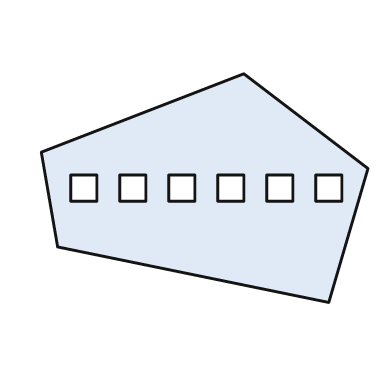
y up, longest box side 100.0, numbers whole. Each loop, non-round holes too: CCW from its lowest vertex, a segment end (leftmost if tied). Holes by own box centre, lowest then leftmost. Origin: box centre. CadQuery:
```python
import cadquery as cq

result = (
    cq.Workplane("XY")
    .moveTo(38.0, -35.0)
    .lineTo(50.0, 6.0)
    .lineTo(12.0, 35.0)
    .lineTo(-50.0, 11.0)
    .lineTo(-45.0, -18.0)
    .close()
    .moveTo(-41.0, -4.0)
    .lineTo(-33.0, -4.0)
    .lineTo(-33.0, 4.0)
    .lineTo(-41.0, 4.0)
    .close()
    .moveTo(-26.0, -4.0)
    .lineTo(-18.0, -4.0)
    .lineTo(-18.0, 4.0)
    .lineTo(-26.0, 4.0)
    .close()
    .moveTo(-11.0, -4.0)
    .lineTo(-3.0, -4.0)
    .lineTo(-3.0, 4.0)
    .lineTo(-11.0, 4.0)
    .close()
    .moveTo(4.0, -4.0)
    .lineTo(12.0, -4.0)
    .lineTo(12.0, 4.0)
    .lineTo(4.0, 4.0)
    .close()
    .moveTo(19.0, -4.0)
    .lineTo(27.0, -4.0)
    .lineTo(27.0, 4.0)
    .lineTo(19.0, 4.0)
    .close()
    .moveTo(34.0, -4.0)
    .lineTo(42.0, -4.0)
    .lineTo(42.0, 4.0)
    .lineTo(34.0, 4.0)
    .close()
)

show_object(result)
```